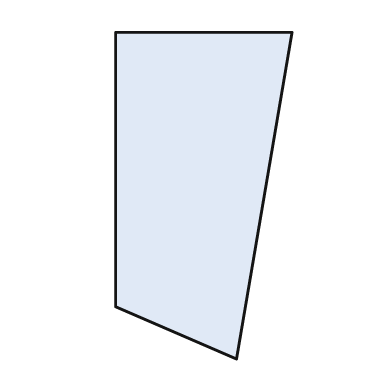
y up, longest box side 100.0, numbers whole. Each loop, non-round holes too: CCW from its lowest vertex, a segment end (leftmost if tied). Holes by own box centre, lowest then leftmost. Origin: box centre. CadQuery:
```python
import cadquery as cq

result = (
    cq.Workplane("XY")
    .moveTo(10.0, -50.0)
    .lineTo(27.0, 50.0)
    .lineTo(-27.0, 50.0)
    .lineTo(-27.0, -34.0)
    .close()
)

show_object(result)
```